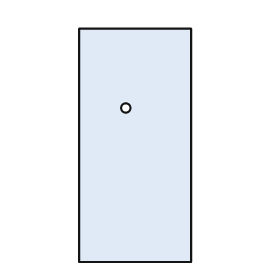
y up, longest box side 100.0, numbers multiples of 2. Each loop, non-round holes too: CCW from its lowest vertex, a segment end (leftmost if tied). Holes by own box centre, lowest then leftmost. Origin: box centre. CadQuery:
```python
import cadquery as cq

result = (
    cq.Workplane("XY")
    .moveTo(-24.0, -50.0)
    .lineTo(24.0, -50.0)
    .lineTo(24.0, 50.0)
    .lineTo(-24.0, 50.0)
    .close()
    .moveTo(-4.0, 16.0)
    .circle(2.0)
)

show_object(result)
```